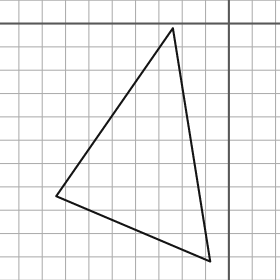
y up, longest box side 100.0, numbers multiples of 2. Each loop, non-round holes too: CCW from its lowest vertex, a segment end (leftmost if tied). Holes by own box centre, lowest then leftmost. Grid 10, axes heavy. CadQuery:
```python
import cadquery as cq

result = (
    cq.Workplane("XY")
    .moveTo(-8.0, -102.0)
    .lineTo(-24.0, -2.0)
    .lineTo(-74.0, -74.0)
    .close()
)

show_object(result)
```